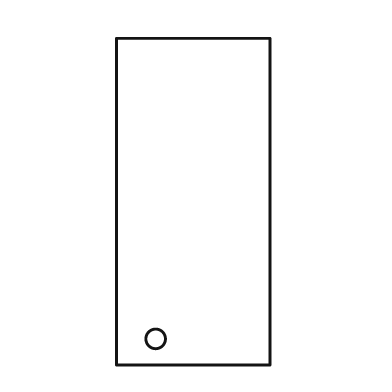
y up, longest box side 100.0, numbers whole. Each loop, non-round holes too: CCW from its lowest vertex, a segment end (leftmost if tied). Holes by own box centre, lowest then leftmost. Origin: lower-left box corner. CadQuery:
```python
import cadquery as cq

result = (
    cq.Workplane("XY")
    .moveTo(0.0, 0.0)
    .lineTo(47.0, 0.0)
    .lineTo(47.0, 100.0)
    .lineTo(0.0, 100.0)
    .close()
    .moveTo(12.0, 8.0)
    .circle(3.0)
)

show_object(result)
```